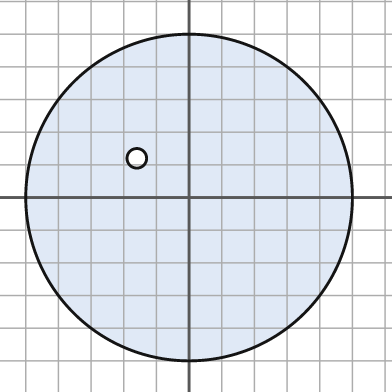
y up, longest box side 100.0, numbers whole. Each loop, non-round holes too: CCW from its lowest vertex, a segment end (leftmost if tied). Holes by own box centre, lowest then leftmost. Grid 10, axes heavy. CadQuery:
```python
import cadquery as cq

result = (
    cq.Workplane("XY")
    .moveTo(0.0, 0.0)
    .circle(50.0)
    .moveTo(-16.0, 12.0)
    .circle(3.0)
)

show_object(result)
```